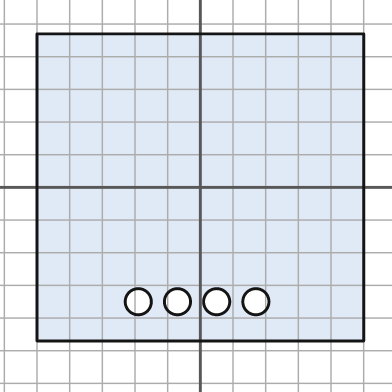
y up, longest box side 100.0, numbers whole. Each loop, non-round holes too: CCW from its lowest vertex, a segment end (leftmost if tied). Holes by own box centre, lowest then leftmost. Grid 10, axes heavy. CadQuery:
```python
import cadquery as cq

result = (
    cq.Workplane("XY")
    .moveTo(-50.0, -47.0)
    .lineTo(50.0, -47.0)
    .lineTo(50.0, 47.0)
    .lineTo(-50.0, 47.0)
    .close()
    .moveTo(-19.0, -35.0)
    .circle(4.0)
    .moveTo(-7.0, -35.0)
    .circle(4.0)
    .moveTo(5.0, -35.0)
    .circle(4.0)
    .moveTo(17.0, -35.0)
    .circle(4.0)
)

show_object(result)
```